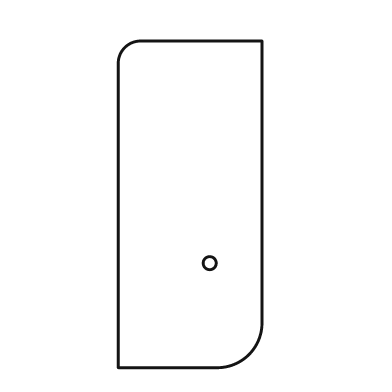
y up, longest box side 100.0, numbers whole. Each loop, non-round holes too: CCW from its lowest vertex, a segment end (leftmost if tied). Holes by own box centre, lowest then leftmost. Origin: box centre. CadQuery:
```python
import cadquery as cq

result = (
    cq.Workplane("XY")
    .moveTo(-22.0, -50.0)
    .lineTo(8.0, -50.0)
    .threePointArc((18.0, -46.0), (22.0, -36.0))
    .lineTo(22.0, 50.0)
    .lineTo(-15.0, 50.0)
    .threePointArc((-20.0, 48.0), (-22.0, 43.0))
    .close()
    .moveTo(6.0, -18.0)
    .circle(2.0)
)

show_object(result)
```